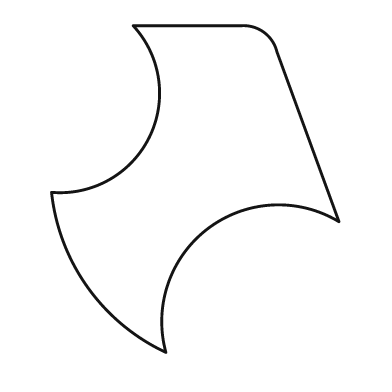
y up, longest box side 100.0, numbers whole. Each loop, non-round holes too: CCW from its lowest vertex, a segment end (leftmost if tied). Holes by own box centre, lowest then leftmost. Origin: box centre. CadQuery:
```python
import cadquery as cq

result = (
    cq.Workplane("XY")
    .moveTo(-9.0, -50.0)
    .threePointArc((4.0, -12.0), (44.0, -10.0))
    .lineTo(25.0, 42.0)
    .threePointArc((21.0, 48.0), (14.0, 50.0))
    .lineTo(-19.0, 50.0)
    .threePointArc((-14.0, 16.0), (-44.0, -1.0))
    .threePointArc((-33.0, -30.0), (-9.0, -50.0))
    .close()
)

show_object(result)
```